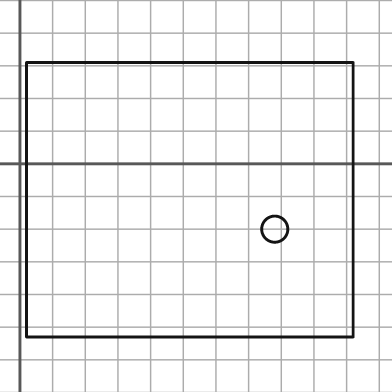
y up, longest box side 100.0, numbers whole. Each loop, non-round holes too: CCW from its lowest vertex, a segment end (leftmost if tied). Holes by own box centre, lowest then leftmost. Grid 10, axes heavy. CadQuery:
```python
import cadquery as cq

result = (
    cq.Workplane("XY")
    .moveTo(2.0, -53.0)
    .lineTo(102.0, -53.0)
    .lineTo(102.0, 31.0)
    .lineTo(2.0, 31.0)
    .close()
    .moveTo(78.0, -20.0)
    .circle(4.0)
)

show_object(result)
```